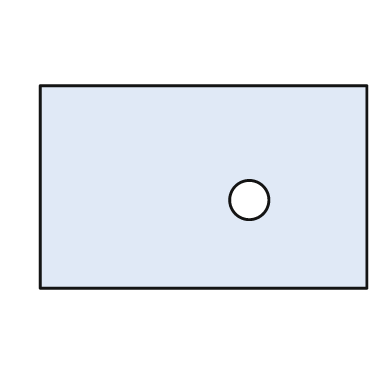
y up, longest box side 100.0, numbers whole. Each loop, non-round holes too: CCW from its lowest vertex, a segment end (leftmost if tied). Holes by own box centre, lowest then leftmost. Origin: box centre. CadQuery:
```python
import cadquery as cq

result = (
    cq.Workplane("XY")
    .moveTo(-50.0, -31.0)
    .lineTo(50.0, -31.0)
    .lineTo(50.0, 31.0)
    .lineTo(-50.0, 31.0)
    .close()
    .moveTo(14.0, -4.0)
    .circle(6.0)
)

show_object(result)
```